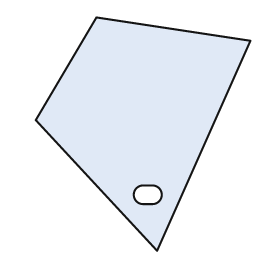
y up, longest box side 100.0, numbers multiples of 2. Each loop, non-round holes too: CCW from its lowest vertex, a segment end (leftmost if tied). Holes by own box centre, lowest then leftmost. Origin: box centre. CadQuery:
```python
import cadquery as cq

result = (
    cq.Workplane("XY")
    .moveTo(6.0, -50.0)
    .lineTo(46.0, 40.0)
    .lineTo(-20.0, 50.0)
    .lineTo(-46.0, 6.0)
    .close()
    .moveTo(0.0, -30.0)
    .lineTo(4.0, -30.0)
    .threePointArc((8.0, -26.0), (4.0, -22.0))
    .lineTo(0.0, -22.0)
    .threePointArc((-4.0, -26.0), (0.0, -30.0))
    .close()
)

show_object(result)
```